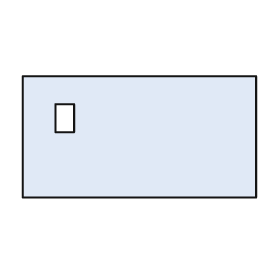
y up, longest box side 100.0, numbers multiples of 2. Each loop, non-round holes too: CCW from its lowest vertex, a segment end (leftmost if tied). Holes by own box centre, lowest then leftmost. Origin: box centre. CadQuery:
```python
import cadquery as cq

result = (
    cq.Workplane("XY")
    .moveTo(-50.0, -26.0)
    .lineTo(50.0, -26.0)
    .lineTo(50.0, 26.0)
    .lineTo(-50.0, 26.0)
    .close()
    .moveTo(-36.0, 2.0)
    .lineTo(-28.0, 2.0)
    .lineTo(-28.0, 14.0)
    .lineTo(-36.0, 14.0)
    .close()
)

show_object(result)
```